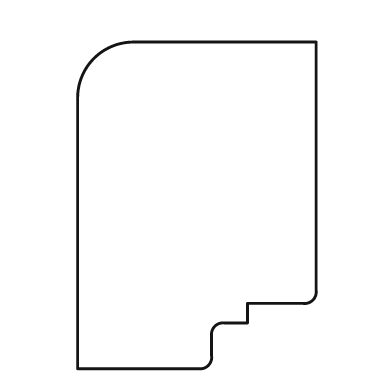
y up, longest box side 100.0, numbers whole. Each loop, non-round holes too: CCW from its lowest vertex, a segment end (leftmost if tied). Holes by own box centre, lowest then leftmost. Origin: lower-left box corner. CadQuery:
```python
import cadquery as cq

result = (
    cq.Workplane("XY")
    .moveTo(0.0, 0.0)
    .lineTo(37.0, 0.0)
    .threePointArc((40.0, 1.0), (41.0, 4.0))
    .lineTo(41.0, 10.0)
    .threePointArc((42.0, 13.0), (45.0, 14.0))
    .lineTo(52.0, 14.0)
    .lineTo(52.0, 20.0)
    .lineTo(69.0, 20.0)
    .threePointArc((72.0, 21.0), (73.0, 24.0))
    .lineTo(73.0, 100.0)
    .lineTo(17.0, 100.0)
    .threePointArc((5.0, 95.0), (0.0, 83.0))
    .close()
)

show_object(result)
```